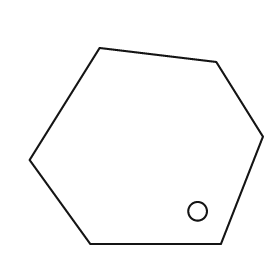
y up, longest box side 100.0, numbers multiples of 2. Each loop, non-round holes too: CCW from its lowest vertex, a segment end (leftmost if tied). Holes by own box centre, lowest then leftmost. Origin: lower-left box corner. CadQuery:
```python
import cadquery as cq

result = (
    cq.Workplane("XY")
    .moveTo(26.0, 0.0)
    .lineTo(82.0, 0.0)
    .lineTo(100.0, 46.0)
    .lineTo(80.0, 78.0)
    .lineTo(30.0, 84.0)
    .lineTo(0.0, 36.0)
    .close()
    .moveTo(72.0, 14.0)
    .circle(4.0)
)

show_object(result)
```